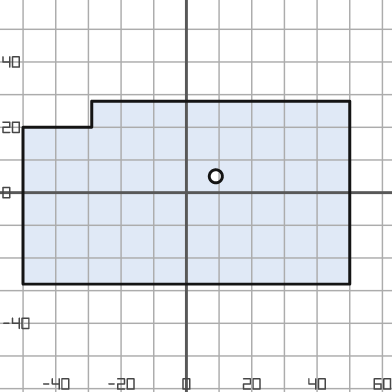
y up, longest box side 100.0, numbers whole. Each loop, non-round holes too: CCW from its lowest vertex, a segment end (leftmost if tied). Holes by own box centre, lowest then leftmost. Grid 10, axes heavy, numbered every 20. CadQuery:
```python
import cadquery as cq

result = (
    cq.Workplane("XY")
    .moveTo(-50.0, -28.0)
    .lineTo(50.0, -28.0)
    .lineTo(50.0, 28.0)
    .lineTo(-29.0, 28.0)
    .lineTo(-29.0, 20.0)
    .lineTo(-50.0, 20.0)
    .close()
    .moveTo(9.0, 5.0)
    .circle(2.0)
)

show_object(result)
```